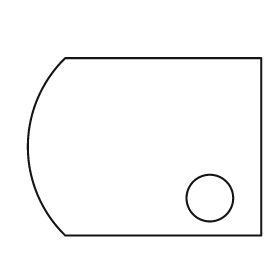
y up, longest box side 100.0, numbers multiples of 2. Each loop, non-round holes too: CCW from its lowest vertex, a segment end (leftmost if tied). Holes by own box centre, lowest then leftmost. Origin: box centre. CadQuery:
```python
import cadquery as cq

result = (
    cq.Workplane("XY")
    .moveTo(-34.0, -38.0)
    .lineTo(50.0, -38.0)
    .lineTo(50.0, 38.0)
    .lineTo(-34.0, 38.0)
    .threePointArc((-50.0, 0.0), (-34.0, -38.0))
    .close()
    .moveTo(28.0, -22.0)
    .circle(10.0)
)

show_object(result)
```